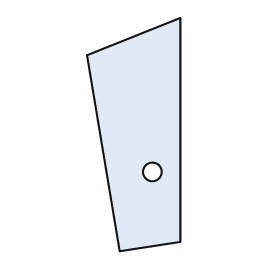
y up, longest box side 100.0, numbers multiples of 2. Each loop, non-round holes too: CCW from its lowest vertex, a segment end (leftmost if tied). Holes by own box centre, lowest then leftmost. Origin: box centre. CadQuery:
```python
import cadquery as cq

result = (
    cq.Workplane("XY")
    .moveTo(-6.0, -50.0)
    .lineTo(20.0, -46.0)
    .lineTo(20.0, 50.0)
    .lineTo(-20.0, 34.0)
    .close()
    .moveTo(8.0, -16.0)
    .circle(4.0)
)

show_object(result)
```